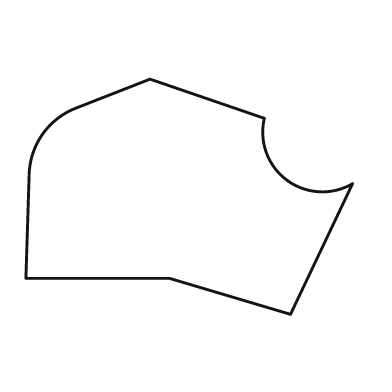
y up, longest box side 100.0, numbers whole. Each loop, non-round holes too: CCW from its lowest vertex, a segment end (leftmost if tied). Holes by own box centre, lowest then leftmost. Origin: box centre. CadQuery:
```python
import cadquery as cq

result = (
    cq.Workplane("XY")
    .moveTo(31.0, -36.0)
    .lineTo(50.0, 4.0)
    .threePointArc((30.0, 5.0), (23.0, 24.0))
    .lineTo(-12.0, 36.0)
    .lineTo(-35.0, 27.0)
    .threePointArc((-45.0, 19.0), (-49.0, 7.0))
    .lineTo(-50.0, -25.0)
    .lineTo(-6.0, -25.0)
    .close()
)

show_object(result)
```